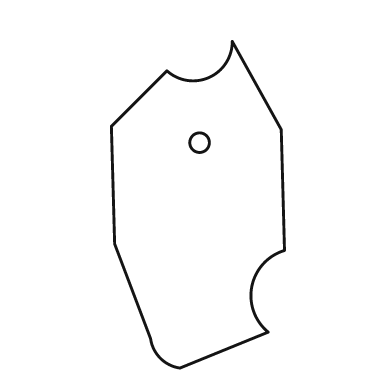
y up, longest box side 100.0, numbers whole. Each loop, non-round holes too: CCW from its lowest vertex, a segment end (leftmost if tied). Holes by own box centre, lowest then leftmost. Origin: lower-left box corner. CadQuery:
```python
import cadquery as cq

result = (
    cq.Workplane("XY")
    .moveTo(21.0, 0.0)
    .lineTo(48.0, 11.0)
    .threePointArc((43.0, 25.0), (53.0, 36.0))
    .lineTo(52.0, 73.0)
    .lineTo(37.0, 100.0)
    .threePointArc((30.0, 89.0), (17.0, 91.0))
    .lineTo(0.0, 74.0)
    .lineTo(1.0, 38.0)
    .lineTo(12.0, 9.0)
    .threePointArc((15.0, 3.0), (21.0, 0.0))
    .close()
    .moveTo(27.0, 69.0)
    .circle(3.0)
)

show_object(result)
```